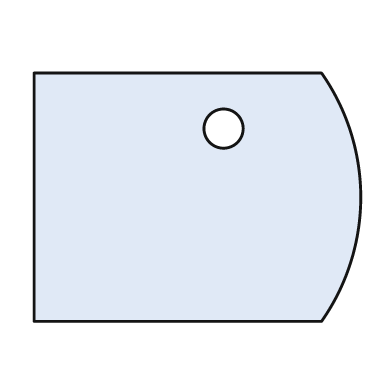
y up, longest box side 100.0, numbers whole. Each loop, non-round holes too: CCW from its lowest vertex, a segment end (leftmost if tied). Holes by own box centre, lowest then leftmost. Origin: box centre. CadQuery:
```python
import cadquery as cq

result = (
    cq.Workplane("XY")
    .moveTo(-50.0, -38.0)
    .lineTo(38.0, -38.0)
    .threePointArc((50.0, 0.0), (38.0, 38.0))
    .lineTo(-50.0, 38.0)
    .close()
    .moveTo(8.0, 21.0)
    .circle(6.0)
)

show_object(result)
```